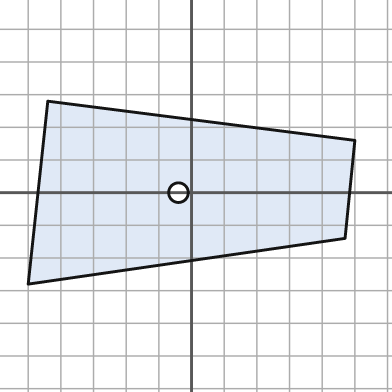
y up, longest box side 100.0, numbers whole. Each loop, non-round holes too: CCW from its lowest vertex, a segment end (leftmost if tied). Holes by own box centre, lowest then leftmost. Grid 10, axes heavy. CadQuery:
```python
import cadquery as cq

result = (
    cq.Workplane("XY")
    .moveTo(-50.0, -28.0)
    .lineTo(47.0, -14.0)
    .lineTo(50.0, 16.0)
    .lineTo(-44.0, 28.0)
    .close()
    .moveTo(-4.0, 0.0)
    .circle(3.0)
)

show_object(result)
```